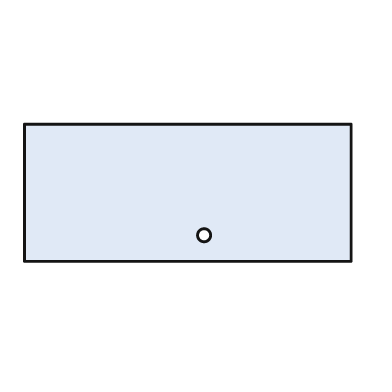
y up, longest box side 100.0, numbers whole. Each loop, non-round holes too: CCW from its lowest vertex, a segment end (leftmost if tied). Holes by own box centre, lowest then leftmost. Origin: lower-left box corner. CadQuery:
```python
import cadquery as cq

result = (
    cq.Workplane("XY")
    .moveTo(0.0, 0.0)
    .lineTo(100.0, 0.0)
    .lineTo(100.0, 42.0)
    .lineTo(0.0, 42.0)
    .close()
    .moveTo(55.0, 8.0)
    .circle(2.0)
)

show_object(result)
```